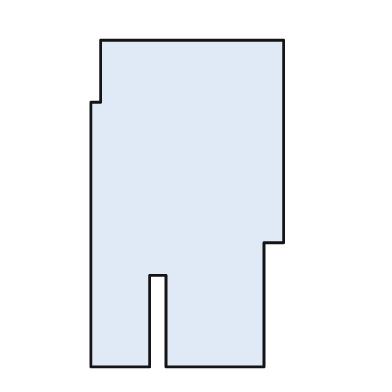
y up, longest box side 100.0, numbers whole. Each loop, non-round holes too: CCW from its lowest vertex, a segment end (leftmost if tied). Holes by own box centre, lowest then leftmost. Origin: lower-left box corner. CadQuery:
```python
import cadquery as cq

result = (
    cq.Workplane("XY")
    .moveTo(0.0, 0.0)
    .lineTo(18.0, 0.0)
    .lineTo(18.0, 28.0)
    .lineTo(23.0, 28.0)
    .lineTo(23.0, 0.0)
    .lineTo(53.0, 0.0)
    .lineTo(53.0, 38.0)
    .lineTo(59.0, 38.0)
    .lineTo(59.0, 100.0)
    .lineTo(3.0, 100.0)
    .lineTo(3.0, 81.0)
    .lineTo(0.0, 81.0)
    .close()
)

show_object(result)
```